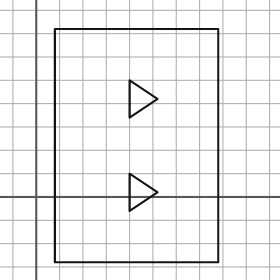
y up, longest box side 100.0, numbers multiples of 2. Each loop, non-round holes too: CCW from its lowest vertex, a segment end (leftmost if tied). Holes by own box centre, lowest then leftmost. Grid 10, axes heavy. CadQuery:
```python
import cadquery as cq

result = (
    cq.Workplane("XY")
    .moveTo(8.0, -28.0)
    .lineTo(78.0, -28.0)
    .lineTo(78.0, 72.0)
    .lineTo(8.0, 72.0)
    .close()
    .moveTo(40.0, -6.0)
    .lineTo(52.0, 2.0)
    .lineTo(40.0, 10.0)
    .close()
    .moveTo(40.0, 34.0)
    .lineTo(52.0, 42.0)
    .lineTo(40.0, 50.0)
    .close()
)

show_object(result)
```